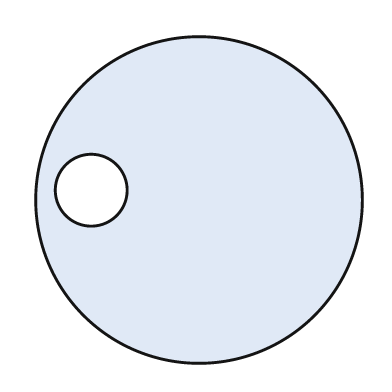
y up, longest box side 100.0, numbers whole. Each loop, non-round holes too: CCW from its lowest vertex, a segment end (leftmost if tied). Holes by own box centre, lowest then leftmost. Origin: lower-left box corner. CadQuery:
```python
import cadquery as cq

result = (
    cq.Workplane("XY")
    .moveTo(50.0, 50.0)
    .circle(50.0)
    .moveTo(17.0, 53.0)
    .circle(11.0)
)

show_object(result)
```